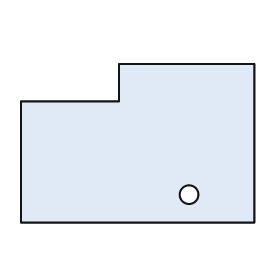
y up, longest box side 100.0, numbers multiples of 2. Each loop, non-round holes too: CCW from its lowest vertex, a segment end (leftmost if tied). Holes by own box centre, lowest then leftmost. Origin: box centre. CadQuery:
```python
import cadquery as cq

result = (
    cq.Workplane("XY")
    .moveTo(-50.0, -34.0)
    .lineTo(50.0, -34.0)
    .lineTo(50.0, 34.0)
    .lineTo(-8.0, 34.0)
    .lineTo(-8.0, 18.0)
    .lineTo(-50.0, 18.0)
    .close()
    .moveTo(22.0, -22.0)
    .circle(4.0)
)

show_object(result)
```